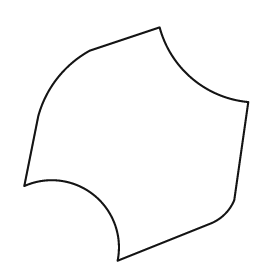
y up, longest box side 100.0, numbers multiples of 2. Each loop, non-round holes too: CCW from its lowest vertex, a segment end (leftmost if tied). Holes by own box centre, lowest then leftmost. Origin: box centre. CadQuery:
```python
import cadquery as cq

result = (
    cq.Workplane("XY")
    .moveTo(-8.0, -50.0)
    .lineTo(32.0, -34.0)
    .threePointArc((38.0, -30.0), (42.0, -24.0))
    .lineTo(48.0, 18.0)
    .threePointArc((24.0, 28.0), (10.0, 50.0))
    .lineTo(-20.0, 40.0)
    .threePointArc((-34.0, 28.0), (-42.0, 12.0))
    .lineTo(-48.0, -18.0)
    .threePointArc((-18.0, -22.0), (-8.0, -50.0))
    .close()
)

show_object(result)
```